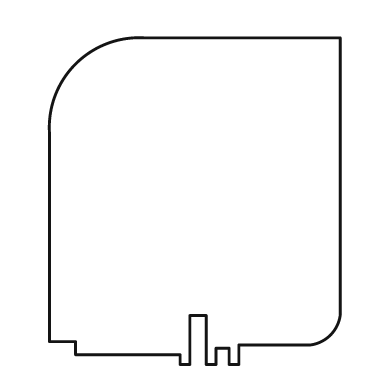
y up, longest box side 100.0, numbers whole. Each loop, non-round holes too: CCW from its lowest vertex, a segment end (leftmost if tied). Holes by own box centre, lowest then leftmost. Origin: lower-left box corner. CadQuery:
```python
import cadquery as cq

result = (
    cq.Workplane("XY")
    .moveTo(40.0, 0.0)
    .lineTo(43.0, 0.0)
    .lineTo(43.0, 15.0)
    .lineTo(48.0, 15.0)
    .lineTo(48.0, 0.0)
    .lineTo(51.0, 0.0)
    .lineTo(51.0, 5.0)
    .lineTo(55.0, 5.0)
    .lineTo(55.0, 0.0)
    .lineTo(58.0, 0.0)
    .lineTo(58.0, 6.0)
    .lineTo(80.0, 6.0)
    .threePointArc((86.0, 9.0), (89.0, 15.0))
    .lineTo(89.0, 100.0)
    .lineTo(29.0, 100.0)
    .threePointArc((8.0, 92.0), (0.0, 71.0))
    .lineTo(0.0, 7.0)
    .lineTo(8.0, 7.0)
    .lineTo(8.0, 3.0)
    .lineTo(40.0, 3.0)
    .close()
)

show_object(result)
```